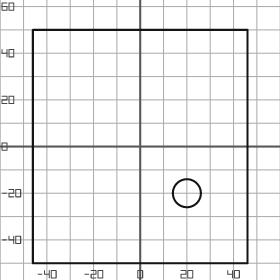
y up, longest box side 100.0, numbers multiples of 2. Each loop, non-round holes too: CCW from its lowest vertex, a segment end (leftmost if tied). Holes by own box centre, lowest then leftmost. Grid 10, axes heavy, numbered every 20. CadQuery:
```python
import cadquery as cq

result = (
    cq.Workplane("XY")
    .moveTo(-46.0, -50.0)
    .lineTo(46.0, -50.0)
    .lineTo(46.0, 50.0)
    .lineTo(-46.0, 50.0)
    .close()
    .moveTo(20.0, -20.0)
    .circle(6.0)
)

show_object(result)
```